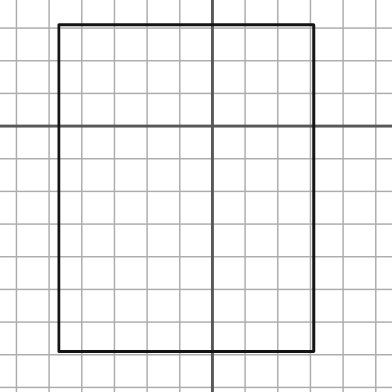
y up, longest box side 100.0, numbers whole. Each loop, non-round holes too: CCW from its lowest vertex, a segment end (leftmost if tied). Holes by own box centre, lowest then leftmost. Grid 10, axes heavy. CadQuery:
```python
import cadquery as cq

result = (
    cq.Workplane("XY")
    .moveTo(-47.0, -69.0)
    .lineTo(31.0, -69.0)
    .lineTo(31.0, 31.0)
    .lineTo(-47.0, 31.0)
    .close()
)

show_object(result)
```